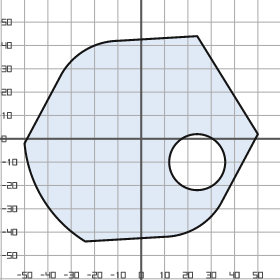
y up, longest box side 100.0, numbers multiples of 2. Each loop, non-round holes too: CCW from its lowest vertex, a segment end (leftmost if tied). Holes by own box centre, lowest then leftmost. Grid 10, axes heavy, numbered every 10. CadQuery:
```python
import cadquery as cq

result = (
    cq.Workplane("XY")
    .moveTo(-24.0, -44.0)
    .lineTo(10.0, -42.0)
    .threePointArc((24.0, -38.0), (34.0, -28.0))
    .lineTo(50.0, 2.0)
    .lineTo(24.0, 44.0)
    .lineTo(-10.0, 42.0)
    .threePointArc((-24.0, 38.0), (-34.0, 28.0))
    .lineTo(-50.0, -2.0)
    .threePointArc((-42.0, -26.0), (-24.0, -44.0))
    .close()
    .moveTo(24.0, -10.0)
    .circle(12.0)
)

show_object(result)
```